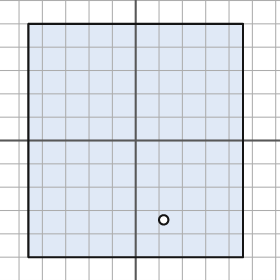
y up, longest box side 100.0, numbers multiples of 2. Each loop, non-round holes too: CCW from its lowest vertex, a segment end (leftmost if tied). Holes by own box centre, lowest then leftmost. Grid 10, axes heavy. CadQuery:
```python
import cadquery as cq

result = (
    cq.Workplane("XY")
    .moveTo(-46.0, -50.0)
    .lineTo(46.0, -50.0)
    .lineTo(46.0, 50.0)
    .lineTo(-46.0, 50.0)
    .close()
    .moveTo(12.0, -34.0)
    .circle(2.0)
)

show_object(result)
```